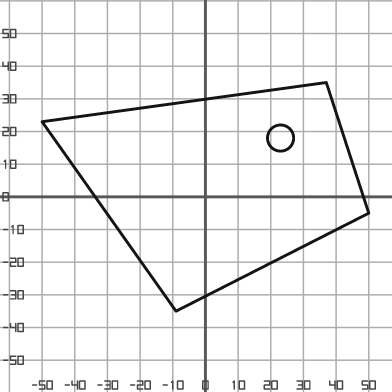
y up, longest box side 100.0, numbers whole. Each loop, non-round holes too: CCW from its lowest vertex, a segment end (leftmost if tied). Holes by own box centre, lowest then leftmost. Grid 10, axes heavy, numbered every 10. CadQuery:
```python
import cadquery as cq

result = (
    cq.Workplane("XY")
    .moveTo(-9.0, -35.0)
    .lineTo(50.0, -5.0)
    .lineTo(37.0, 35.0)
    .lineTo(-50.0, 23.0)
    .close()
    .moveTo(23.0, 18.0)
    .circle(4.0)
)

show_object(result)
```